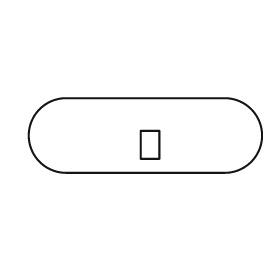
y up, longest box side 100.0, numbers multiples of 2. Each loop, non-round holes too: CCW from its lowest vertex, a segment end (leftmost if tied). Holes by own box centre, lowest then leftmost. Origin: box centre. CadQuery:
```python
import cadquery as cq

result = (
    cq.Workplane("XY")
    .moveTo(-34.0, -16.0)
    .lineTo(34.0, -16.0)
    .threePointArc((50.0, 0.0), (34.0, 16.0))
    .lineTo(-34.0, 16.0)
    .threePointArc((-50.0, 0.0), (-34.0, -16.0))
    .close()
    .moveTo(-2.0, -10.0)
    .lineTo(6.0, -10.0)
    .lineTo(6.0, 2.0)
    .lineTo(-2.0, 2.0)
    .close()
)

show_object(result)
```